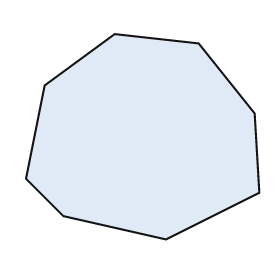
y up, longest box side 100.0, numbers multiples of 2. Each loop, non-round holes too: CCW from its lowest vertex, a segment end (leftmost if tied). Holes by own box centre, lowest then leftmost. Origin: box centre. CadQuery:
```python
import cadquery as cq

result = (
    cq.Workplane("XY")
    .moveTo(10.0, -44.0)
    .lineTo(50.0, -24.0)
    .lineTo(48.0, 10.0)
    .lineTo(24.0, 40.0)
    .lineTo(-12.0, 44.0)
    .lineTo(-42.0, 22.0)
    .lineTo(-50.0, -18.0)
    .lineTo(-34.0, -34.0)
    .close()
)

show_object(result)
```